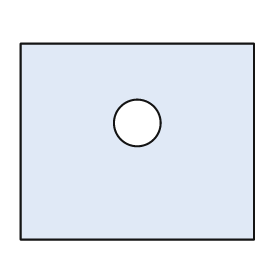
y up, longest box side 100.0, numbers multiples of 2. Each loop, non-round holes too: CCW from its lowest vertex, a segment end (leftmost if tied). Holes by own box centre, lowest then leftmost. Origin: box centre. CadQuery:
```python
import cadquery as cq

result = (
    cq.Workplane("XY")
    .moveTo(-50.0, -42.0)
    .lineTo(50.0, -42.0)
    .lineTo(50.0, 42.0)
    .lineTo(-50.0, 42.0)
    .close()
    .moveTo(0.0, 8.0)
    .circle(10.0)
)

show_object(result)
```